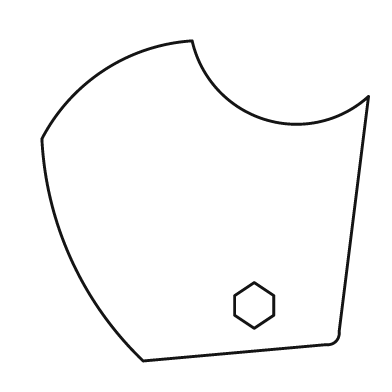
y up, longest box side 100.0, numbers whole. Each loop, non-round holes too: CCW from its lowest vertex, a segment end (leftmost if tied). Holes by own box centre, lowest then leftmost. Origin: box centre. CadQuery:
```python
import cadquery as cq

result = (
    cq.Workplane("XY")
    .moveTo(-19.0, -49.0)
    .lineTo(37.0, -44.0)
    .threePointArc((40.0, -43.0), (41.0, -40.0))
    .lineTo(50.0, 32.0)
    .threePointArc((18.0, 25.0), (-4.0, 49.0))
    .threePointArc((-31.0, 40.0), (-50.0, 19.0))
    .threePointArc((-41.0, -18.0), (-19.0, -49.0))
    .close()
    .moveTo(15.0, -39.0)
    .lineTo(21.0, -35.0)
    .lineTo(21.0, -29.0)
    .lineTo(15.0, -25.0)
    .lineTo(9.0, -29.0)
    .lineTo(9.0, -35.0)
    .close()
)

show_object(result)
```